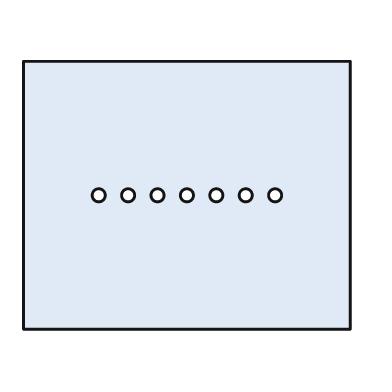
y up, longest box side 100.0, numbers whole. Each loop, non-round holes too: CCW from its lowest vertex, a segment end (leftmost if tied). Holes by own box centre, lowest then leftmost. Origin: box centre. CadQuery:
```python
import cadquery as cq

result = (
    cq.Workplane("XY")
    .moveTo(-50.0, -41.0)
    .lineTo(50.0, -41.0)
    .lineTo(50.0, 41.0)
    .lineTo(-50.0, 41.0)
    .close()
    .moveTo(-27.0, 0.0)
    .circle(2.0)
    .moveTo(-18.0, 0.0)
    .circle(2.0)
    .moveTo(-9.0, 0.0)
    .circle(2.0)
    .moveTo(0.0, 0.0)
    .circle(2.0)
    .moveTo(9.0, 0.0)
    .circle(2.0)
    .moveTo(18.0, 0.0)
    .circle(2.0)
    .moveTo(27.0, 0.0)
    .circle(2.0)
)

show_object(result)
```